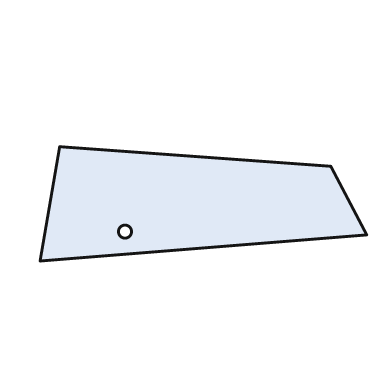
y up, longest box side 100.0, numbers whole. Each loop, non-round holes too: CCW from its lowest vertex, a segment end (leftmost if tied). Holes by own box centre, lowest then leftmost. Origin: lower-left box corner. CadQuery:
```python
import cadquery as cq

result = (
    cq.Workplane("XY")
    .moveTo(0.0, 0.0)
    .lineTo(100.0, 8.0)
    .lineTo(89.0, 29.0)
    .lineTo(6.0, 35.0)
    .close()
    .moveTo(26.0, 9.0)
    .circle(2.0)
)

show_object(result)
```